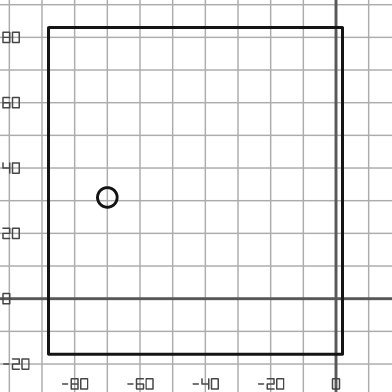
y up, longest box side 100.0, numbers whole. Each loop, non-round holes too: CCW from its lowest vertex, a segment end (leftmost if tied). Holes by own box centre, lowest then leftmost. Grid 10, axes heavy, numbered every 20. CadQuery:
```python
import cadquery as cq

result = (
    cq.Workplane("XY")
    .moveTo(-88.0, -17.0)
    .lineTo(2.0, -17.0)
    .lineTo(2.0, 83.0)
    .lineTo(-88.0, 83.0)
    .close()
    .moveTo(-70.0, 31.0)
    .circle(3.0)
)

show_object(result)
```